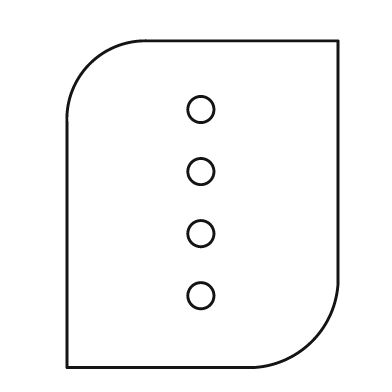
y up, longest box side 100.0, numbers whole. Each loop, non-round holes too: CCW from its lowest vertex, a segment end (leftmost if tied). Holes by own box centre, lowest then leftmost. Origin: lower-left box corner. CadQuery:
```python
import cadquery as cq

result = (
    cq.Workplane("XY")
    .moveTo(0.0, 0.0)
    .lineTo(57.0, 0.0)
    .threePointArc((75.0, 8.0), (83.0, 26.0))
    .lineTo(83.0, 100.0)
    .lineTo(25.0, 100.0)
    .threePointArc((7.0, 93.0), (0.0, 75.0))
    .close()
    .moveTo(41.0, 22.0)
    .circle(4.0)
    .moveTo(41.0, 41.0)
    .circle(4.0)
    .moveTo(41.0, 60.0)
    .circle(4.0)
    .moveTo(41.0, 79.0)
    .circle(4.0)
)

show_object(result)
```